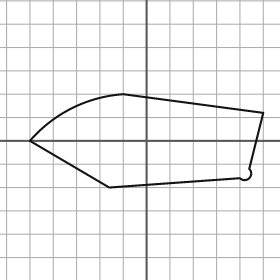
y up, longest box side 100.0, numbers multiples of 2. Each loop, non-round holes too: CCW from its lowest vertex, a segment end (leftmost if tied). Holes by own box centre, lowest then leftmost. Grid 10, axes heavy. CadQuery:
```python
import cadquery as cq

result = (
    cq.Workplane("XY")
    .moveTo(-16.0, -20.0)
    .lineTo(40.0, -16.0)
    .threePointArc((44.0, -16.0), (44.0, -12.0))
    .lineTo(50.0, 12.0)
    .lineTo(-10.0, 20.0)
    .threePointArc((-32.0, 14.0), (-50.0, 0.0))
    .close()
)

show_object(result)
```